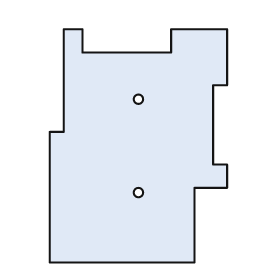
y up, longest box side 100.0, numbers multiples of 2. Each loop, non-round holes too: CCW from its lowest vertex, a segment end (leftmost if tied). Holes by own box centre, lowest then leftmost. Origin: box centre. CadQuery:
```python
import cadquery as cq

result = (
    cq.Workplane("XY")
    .moveTo(-38.0, -50.0)
    .lineTo(24.0, -50.0)
    .lineTo(24.0, -18.0)
    .lineTo(38.0, -18.0)
    .lineTo(38.0, -8.0)
    .lineTo(32.0, -8.0)
    .lineTo(32.0, 26.0)
    .lineTo(38.0, 26.0)
    .lineTo(38.0, 50.0)
    .lineTo(14.0, 50.0)
    .lineTo(14.0, 40.0)
    .lineTo(-24.0, 40.0)
    .lineTo(-24.0, 50.0)
    .lineTo(-32.0, 50.0)
    .lineTo(-32.0, 6.0)
    .lineTo(-38.0, 6.0)
    .close()
    .moveTo(0.0, -20.0)
    .circle(2.0)
    .moveTo(0.0, 20.0)
    .circle(2.0)
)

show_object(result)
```